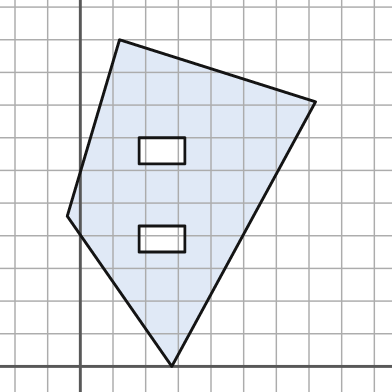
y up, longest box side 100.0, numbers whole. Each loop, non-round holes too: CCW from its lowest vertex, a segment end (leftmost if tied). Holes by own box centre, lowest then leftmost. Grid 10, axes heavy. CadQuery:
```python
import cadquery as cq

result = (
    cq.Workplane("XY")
    .moveTo(28.0, 0.0)
    .lineTo(72.0, 81.0)
    .lineTo(12.0, 100.0)
    .lineTo(-4.0, 46.0)
    .close()
    .moveTo(18.0, 35.0)
    .lineTo(32.0, 35.0)
    .lineTo(32.0, 43.0)
    .lineTo(18.0, 43.0)
    .close()
    .moveTo(18.0, 62.0)
    .lineTo(32.0, 62.0)
    .lineTo(32.0, 70.0)
    .lineTo(18.0, 70.0)
    .close()
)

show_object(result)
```